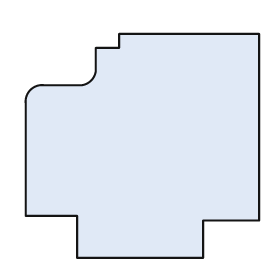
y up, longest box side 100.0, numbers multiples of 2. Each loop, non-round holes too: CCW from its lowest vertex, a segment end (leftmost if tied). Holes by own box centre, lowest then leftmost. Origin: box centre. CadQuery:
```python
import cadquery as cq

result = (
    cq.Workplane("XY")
    .moveTo(-28.0, -48.0)
    .lineTo(26.0, -48.0)
    .lineTo(26.0, -32.0)
    .lineTo(50.0, -32.0)
    .lineTo(50.0, 48.0)
    .lineTo(-10.0, 48.0)
    .lineTo(-10.0, 42.0)
    .lineTo(-20.0, 42.0)
    .lineTo(-20.0, 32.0)
    .threePointArc((-22.0, 28.0), (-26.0, 26.0))
    .lineTo(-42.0, 26.0)
    .threePointArc((-48.0, 24.0), (-50.0, 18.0))
    .lineTo(-50.0, -30.0)
    .lineTo(-28.0, -30.0)
    .close()
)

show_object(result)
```